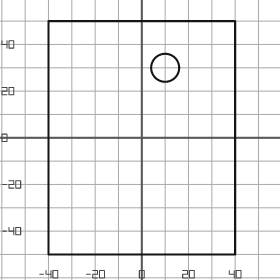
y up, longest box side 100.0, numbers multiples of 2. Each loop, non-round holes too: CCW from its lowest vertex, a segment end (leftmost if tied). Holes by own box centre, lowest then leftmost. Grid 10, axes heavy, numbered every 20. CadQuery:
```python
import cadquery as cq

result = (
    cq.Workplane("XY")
    .moveTo(-40.0, -50.0)
    .lineTo(40.0, -50.0)
    .lineTo(40.0, 50.0)
    .lineTo(-40.0, 50.0)
    .close()
    .moveTo(10.0, 30.0)
    .circle(6.0)
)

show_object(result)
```